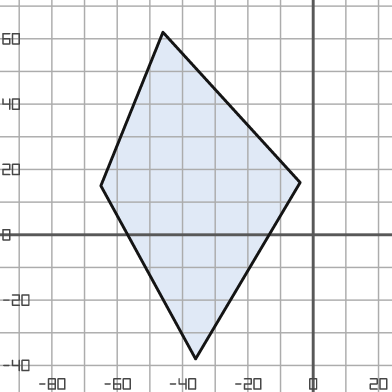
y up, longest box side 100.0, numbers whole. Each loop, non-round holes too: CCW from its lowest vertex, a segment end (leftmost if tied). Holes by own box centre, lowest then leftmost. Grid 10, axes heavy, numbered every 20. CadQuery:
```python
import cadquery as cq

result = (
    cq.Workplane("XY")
    .moveTo(-36.0, -38.0)
    .lineTo(-4.0, 16.0)
    .lineTo(-46.0, 62.0)
    .lineTo(-65.0, 15.0)
    .close()
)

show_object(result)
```